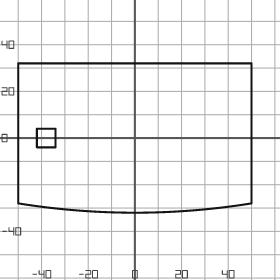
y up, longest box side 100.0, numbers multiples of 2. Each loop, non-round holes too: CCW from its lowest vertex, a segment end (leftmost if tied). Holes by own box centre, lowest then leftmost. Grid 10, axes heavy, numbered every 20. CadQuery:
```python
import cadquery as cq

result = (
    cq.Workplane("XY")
    .moveTo(-50.0, -28.0)
    .threePointArc((0.0, -32.0), (50.0, -28.0))
    .lineTo(50.0, 32.0)
    .lineTo(-50.0, 32.0)
    .close()
    .moveTo(-42.0, -4.0)
    .lineTo(-34.0, -4.0)
    .lineTo(-34.0, 4.0)
    .lineTo(-42.0, 4.0)
    .close()
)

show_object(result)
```